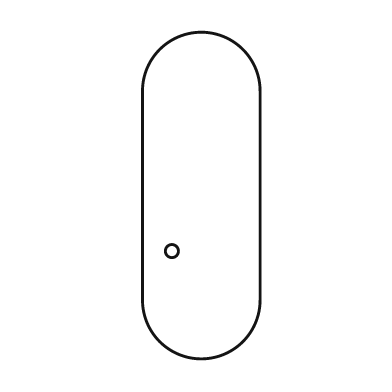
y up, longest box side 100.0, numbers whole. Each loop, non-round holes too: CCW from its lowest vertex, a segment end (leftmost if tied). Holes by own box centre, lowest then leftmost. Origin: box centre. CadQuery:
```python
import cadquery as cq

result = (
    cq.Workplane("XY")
    .moveTo(-18.0, -32.0)
    .threePointArc((0.0, -50.0), (18.0, -32.0))
    .lineTo(18.0, 32.0)
    .threePointArc((0.0, 50.0), (-18.0, 32.0))
    .close()
    .moveTo(-9.0, -17.0)
    .circle(2.0)
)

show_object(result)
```